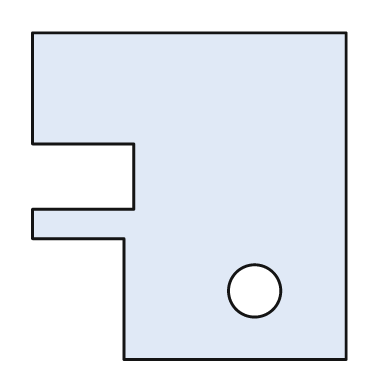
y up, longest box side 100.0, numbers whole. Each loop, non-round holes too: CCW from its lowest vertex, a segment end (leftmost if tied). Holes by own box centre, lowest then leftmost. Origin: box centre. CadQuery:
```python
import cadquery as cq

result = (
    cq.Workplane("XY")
    .moveTo(-20.0, -50.0)
    .lineTo(48.0, -50.0)
    .lineTo(48.0, 50.0)
    .lineTo(-48.0, 50.0)
    .lineTo(-48.0, 16.0)
    .lineTo(-17.0, 16.0)
    .lineTo(-17.0, -4.0)
    .lineTo(-48.0, -4.0)
    .lineTo(-48.0, -13.0)
    .lineTo(-20.0, -13.0)
    .close()
    .moveTo(20.0, -29.0)
    .circle(8.0)
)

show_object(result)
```